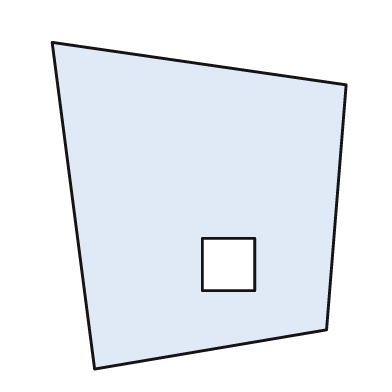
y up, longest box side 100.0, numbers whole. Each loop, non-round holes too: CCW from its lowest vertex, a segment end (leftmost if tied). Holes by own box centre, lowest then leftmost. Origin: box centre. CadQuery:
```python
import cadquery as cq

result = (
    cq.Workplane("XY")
    .moveTo(-32.0, -50.0)
    .lineTo(39.0, -38.0)
    .lineTo(45.0, 37.0)
    .lineTo(-45.0, 50.0)
    .close()
    .moveTo(1.0, -26.0)
    .lineTo(17.0, -26.0)
    .lineTo(17.0, -10.0)
    .lineTo(1.0, -10.0)
    .close()
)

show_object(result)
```